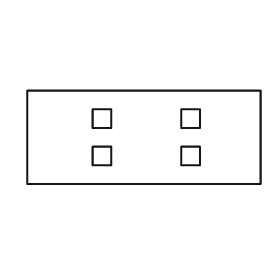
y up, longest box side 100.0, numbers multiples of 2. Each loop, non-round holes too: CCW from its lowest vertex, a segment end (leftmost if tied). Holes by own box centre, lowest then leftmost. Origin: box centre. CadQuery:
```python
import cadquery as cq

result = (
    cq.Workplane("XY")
    .moveTo(-50.0, -20.0)
    .lineTo(50.0, -20.0)
    .lineTo(50.0, 20.0)
    .lineTo(-50.0, 20.0)
    .close()
    .moveTo(-22.0, -12.0)
    .lineTo(-14.0, -12.0)
    .lineTo(-14.0, -4.0)
    .lineTo(-22.0, -4.0)
    .close()
    .moveTo(16.0, -12.0)
    .lineTo(24.0, -12.0)
    .lineTo(24.0, -4.0)
    .lineTo(16.0, -4.0)
    .close()
    .moveTo(-22.0, 4.0)
    .lineTo(-14.0, 4.0)
    .lineTo(-14.0, 12.0)
    .lineTo(-22.0, 12.0)
    .close()
    .moveTo(16.0, 4.0)
    .lineTo(24.0, 4.0)
    .lineTo(24.0, 12.0)
    .lineTo(16.0, 12.0)
    .close()
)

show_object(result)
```